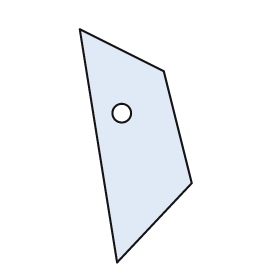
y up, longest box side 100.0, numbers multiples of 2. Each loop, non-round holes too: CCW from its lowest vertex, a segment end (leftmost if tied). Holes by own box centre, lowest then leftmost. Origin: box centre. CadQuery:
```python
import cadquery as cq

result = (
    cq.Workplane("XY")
    .moveTo(-8.0, -50.0)
    .lineTo(24.0, -16.0)
    .lineTo(12.0, 32.0)
    .lineTo(-24.0, 50.0)
    .close()
    .moveTo(-6.0, 14.0)
    .circle(4.0)
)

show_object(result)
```